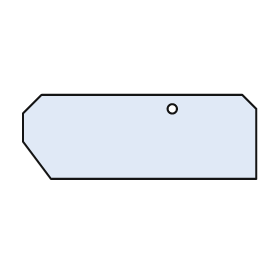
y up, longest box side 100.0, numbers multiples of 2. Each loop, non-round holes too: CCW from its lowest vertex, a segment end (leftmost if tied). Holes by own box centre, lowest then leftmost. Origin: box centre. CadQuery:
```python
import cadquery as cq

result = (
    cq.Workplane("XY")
    .moveTo(-38.0, -18.0)
    .lineTo(50.0, -18.0)
    .lineTo(50.0, 12.0)
    .lineTo(44.0, 18.0)
    .lineTo(-42.0, 18.0)
    .lineTo(-50.0, 10.0)
    .lineTo(-50.0, -2.0)
    .close()
    .moveTo(14.0, 12.0)
    .circle(2.0)
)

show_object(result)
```